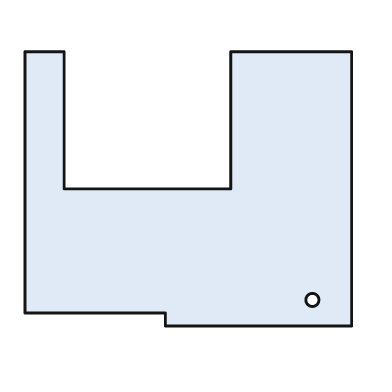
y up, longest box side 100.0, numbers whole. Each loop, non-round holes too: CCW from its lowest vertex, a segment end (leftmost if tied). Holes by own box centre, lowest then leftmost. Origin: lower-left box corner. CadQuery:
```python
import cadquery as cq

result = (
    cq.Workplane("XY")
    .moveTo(43.0, 0.0)
    .lineTo(100.0, 0.0)
    .lineTo(100.0, 84.0)
    .lineTo(63.0, 84.0)
    .lineTo(63.0, 42.0)
    .lineTo(12.0, 42.0)
    .lineTo(12.0, 84.0)
    .lineTo(0.0, 84.0)
    .lineTo(0.0, 4.0)
    .lineTo(43.0, 4.0)
    .close()
    .moveTo(88.0, 8.0)
    .circle(2.0)
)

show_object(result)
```